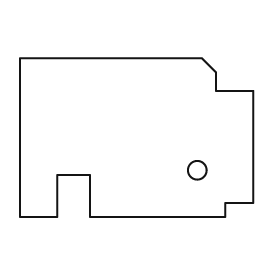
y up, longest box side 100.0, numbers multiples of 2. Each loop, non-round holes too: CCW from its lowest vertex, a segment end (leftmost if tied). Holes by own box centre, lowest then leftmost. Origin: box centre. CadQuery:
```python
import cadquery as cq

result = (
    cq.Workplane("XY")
    .moveTo(-50.0, -34.0)
    .lineTo(-34.0, -34.0)
    .lineTo(-34.0, -16.0)
    .lineTo(-20.0, -16.0)
    .lineTo(-20.0, -34.0)
    .lineTo(38.0, -34.0)
    .lineTo(38.0, -28.0)
    .lineTo(50.0, -28.0)
    .lineTo(50.0, 20.0)
    .lineTo(34.0, 20.0)
    .lineTo(34.0, 28.0)
    .lineTo(28.0, 34.0)
    .lineTo(-50.0, 34.0)
    .close()
    .moveTo(26.0, -14.0)
    .circle(4.0)
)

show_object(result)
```